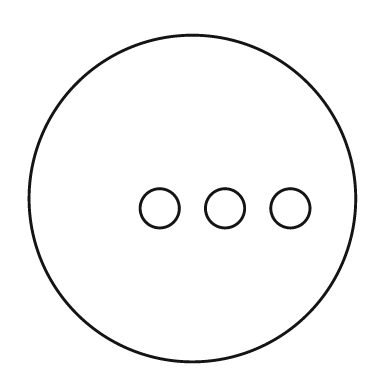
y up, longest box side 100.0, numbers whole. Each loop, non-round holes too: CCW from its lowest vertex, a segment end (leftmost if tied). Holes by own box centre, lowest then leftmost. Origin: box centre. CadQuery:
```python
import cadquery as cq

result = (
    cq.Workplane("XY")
    .moveTo(0.0, 0.0)
    .circle(50.0)
    .moveTo(-10.0, -3.0)
    .circle(6.0)
    .moveTo(10.0, -3.0)
    .circle(6.0)
    .moveTo(30.0, -3.0)
    .circle(6.0)
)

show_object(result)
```